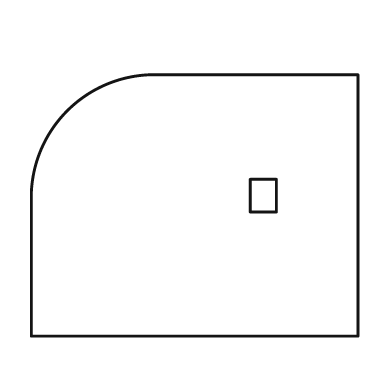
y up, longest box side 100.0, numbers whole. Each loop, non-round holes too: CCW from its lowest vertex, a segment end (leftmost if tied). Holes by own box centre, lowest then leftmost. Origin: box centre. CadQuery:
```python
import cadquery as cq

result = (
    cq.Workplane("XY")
    .moveTo(-50.0, -40.0)
    .lineTo(50.0, -40.0)
    .lineTo(50.0, 40.0)
    .lineTo(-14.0, 40.0)
    .threePointArc((-39.0, 29.0), (-50.0, 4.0))
    .close()
    .moveTo(17.0, -2.0)
    .lineTo(25.0, -2.0)
    .lineTo(25.0, 8.0)
    .lineTo(17.0, 8.0)
    .close()
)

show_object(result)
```